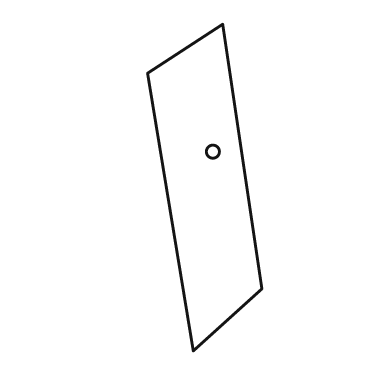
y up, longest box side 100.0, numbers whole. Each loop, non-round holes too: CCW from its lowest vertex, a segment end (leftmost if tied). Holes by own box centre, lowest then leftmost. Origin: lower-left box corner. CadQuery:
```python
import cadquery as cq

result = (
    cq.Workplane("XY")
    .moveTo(14.0, 0.0)
    .lineTo(35.0, 19.0)
    .lineTo(23.0, 100.0)
    .lineTo(0.0, 85.0)
    .close()
    .moveTo(20.0, 61.0)
    .circle(2.0)
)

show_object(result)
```